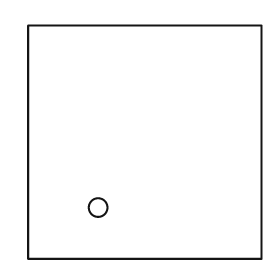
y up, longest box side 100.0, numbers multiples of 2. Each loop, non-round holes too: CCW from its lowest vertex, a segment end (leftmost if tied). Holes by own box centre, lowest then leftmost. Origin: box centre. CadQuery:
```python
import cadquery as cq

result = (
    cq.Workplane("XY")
    .moveTo(-50.0, -50.0)
    .lineTo(50.0, -50.0)
    .lineTo(50.0, 50.0)
    .lineTo(-50.0, 50.0)
    .close()
    .moveTo(-20.0, -28.0)
    .circle(4.0)
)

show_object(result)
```